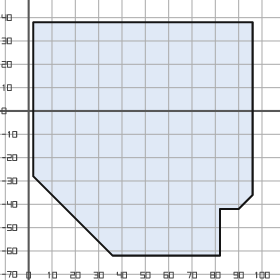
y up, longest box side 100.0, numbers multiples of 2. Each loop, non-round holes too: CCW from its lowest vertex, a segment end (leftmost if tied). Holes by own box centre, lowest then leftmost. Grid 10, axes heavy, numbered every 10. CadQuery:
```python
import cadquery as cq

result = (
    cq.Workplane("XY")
    .moveTo(36.0, -62.0)
    .lineTo(82.0, -62.0)
    .lineTo(82.0, -42.0)
    .lineTo(90.0, -42.0)
    .lineTo(96.0, -36.0)
    .lineTo(96.0, 38.0)
    .lineTo(2.0, 38.0)
    .lineTo(2.0, -28.0)
    .close()
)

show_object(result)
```